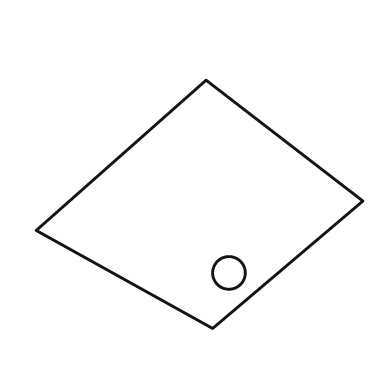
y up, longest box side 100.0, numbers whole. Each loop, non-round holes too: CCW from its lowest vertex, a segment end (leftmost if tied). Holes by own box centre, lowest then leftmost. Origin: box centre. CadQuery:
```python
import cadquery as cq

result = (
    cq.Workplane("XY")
    .moveTo(4.0, -38.0)
    .lineTo(50.0, 1.0)
    .lineTo(2.0, 38.0)
    .lineTo(-50.0, -8.0)
    .close()
    .moveTo(9.0, -21.0)
    .circle(5.0)
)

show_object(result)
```